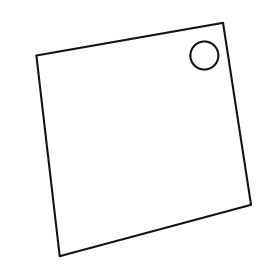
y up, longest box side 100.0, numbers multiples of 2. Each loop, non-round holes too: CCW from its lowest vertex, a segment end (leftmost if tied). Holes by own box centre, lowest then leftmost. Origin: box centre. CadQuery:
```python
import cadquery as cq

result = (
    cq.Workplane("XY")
    .moveTo(-36.0, -50.0)
    .lineTo(46.0, -28.0)
    .lineTo(34.0, 50.0)
    .lineTo(-46.0, 36.0)
    .close()
    .moveTo(26.0, 36.0)
    .circle(6.0)
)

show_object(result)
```